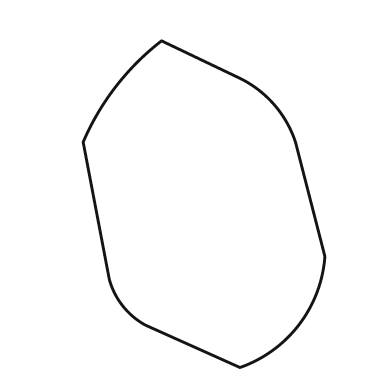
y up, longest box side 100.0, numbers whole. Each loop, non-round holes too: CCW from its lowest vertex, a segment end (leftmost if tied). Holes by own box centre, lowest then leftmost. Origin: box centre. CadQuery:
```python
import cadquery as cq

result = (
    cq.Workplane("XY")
    .moveTo(11.0, -50.0)
    .threePointArc((29.0, -37.0), (37.0, -16.0))
    .lineTo(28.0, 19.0)
    .threePointArc((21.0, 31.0), (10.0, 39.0))
    .lineTo(-13.0, 50.0)
    .threePointArc((-27.0, 36.0), (-37.0, 19.0))
    .lineTo(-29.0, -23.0)
    .threePointArc((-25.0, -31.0), (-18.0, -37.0))
    .close()
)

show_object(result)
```